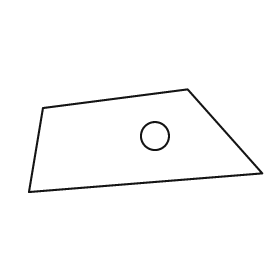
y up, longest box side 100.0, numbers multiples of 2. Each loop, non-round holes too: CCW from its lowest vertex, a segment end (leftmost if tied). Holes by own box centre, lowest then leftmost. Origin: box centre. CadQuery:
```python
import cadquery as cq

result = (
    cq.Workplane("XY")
    .moveTo(-50.0, -22.0)
    .lineTo(50.0, -14.0)
    .lineTo(18.0, 22.0)
    .lineTo(-44.0, 14.0)
    .close()
    .moveTo(4.0, 2.0)
    .circle(6.0)
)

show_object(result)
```